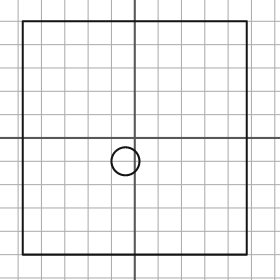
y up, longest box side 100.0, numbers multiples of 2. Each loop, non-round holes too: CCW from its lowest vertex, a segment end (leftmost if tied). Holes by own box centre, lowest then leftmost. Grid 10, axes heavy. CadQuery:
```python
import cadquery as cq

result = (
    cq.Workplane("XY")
    .moveTo(-48.0, -50.0)
    .lineTo(48.0, -50.0)
    .lineTo(48.0, 50.0)
    .lineTo(-48.0, 50.0)
    .close()
    .moveTo(-4.0, -10.0)
    .circle(6.0)
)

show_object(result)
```